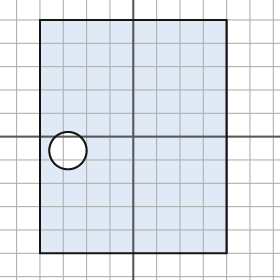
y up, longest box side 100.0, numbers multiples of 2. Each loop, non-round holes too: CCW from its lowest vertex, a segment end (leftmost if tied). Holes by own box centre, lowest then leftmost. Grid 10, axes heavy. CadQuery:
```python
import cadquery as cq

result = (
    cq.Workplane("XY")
    .moveTo(-40.0, -50.0)
    .lineTo(40.0, -50.0)
    .lineTo(40.0, 50.0)
    .lineTo(-40.0, 50.0)
    .close()
    .moveTo(-28.0, -6.0)
    .circle(8.0)
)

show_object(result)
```